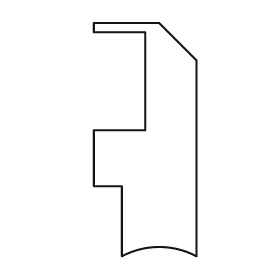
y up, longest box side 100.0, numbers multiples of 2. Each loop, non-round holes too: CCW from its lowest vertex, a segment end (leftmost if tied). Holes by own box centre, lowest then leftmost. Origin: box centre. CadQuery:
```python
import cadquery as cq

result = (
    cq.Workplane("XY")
    .moveTo(-10.0, -50.0)
    .threePointArc((6.0, -46.0), (22.0, -50.0))
    .lineTo(22.0, 34.0)
    .lineTo(6.0, 50.0)
    .lineTo(-22.0, 50.0)
    .lineTo(-22.0, 46.0)
    .lineTo(0.0, 46.0)
    .lineTo(0.0, 4.0)
    .lineTo(-22.0, 4.0)
    .lineTo(-22.0, -20.0)
    .lineTo(-10.0, -20.0)
    .close()
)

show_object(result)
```